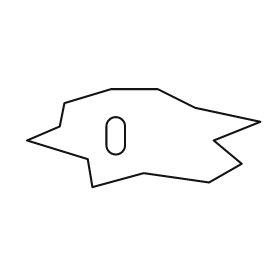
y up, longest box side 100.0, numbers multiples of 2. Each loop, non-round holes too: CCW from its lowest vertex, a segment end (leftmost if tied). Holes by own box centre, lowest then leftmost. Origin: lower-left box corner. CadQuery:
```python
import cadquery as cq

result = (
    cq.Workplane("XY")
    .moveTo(28.0, 0.0)
    .lineTo(50.0, 6.0)
    .lineTo(78.0, 2.0)
    .lineTo(92.0, 10.0)
    .lineTo(80.0, 20.0)
    .lineTo(100.0, 28.0)
    .lineTo(72.0, 34.0)
    .lineTo(56.0, 42.0)
    .lineTo(36.0, 42.0)
    .lineTo(16.0, 36.0)
    .lineTo(14.0, 26.0)
    .lineTo(0.0, 20.0)
    .lineTo(26.0, 12.0)
    .close()
    .moveTo(34.0, 18.0)
    .threePointArc((38.0, 14.0), (42.0, 18.0))
    .lineTo(42.0, 26.0)
    .threePointArc((38.0, 30.0), (34.0, 26.0))
    .close()
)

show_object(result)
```